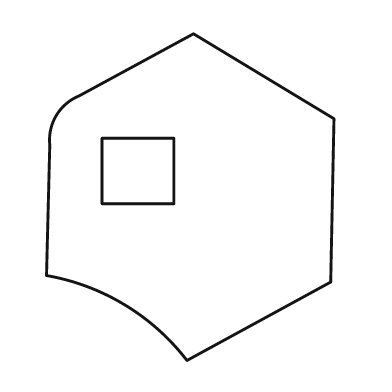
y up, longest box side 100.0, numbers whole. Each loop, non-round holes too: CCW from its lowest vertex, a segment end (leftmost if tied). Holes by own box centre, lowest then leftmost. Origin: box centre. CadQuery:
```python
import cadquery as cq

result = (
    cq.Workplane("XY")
    .moveTo(-1.0, -50.0)
    .lineTo(43.0, -26.0)
    .lineTo(44.0, 24.0)
    .lineTo(1.0, 50.0)
    .lineTo(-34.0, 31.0)
    .threePointArc((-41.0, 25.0), (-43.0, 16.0))
    .lineTo(-44.0, -24.0)
    .threePointArc((-20.0, -33.0), (-1.0, -50.0))
    .close()
    .moveTo(-27.0, -2.0)
    .lineTo(-5.0, -2.0)
    .lineTo(-5.0, 18.0)
    .lineTo(-27.0, 18.0)
    .close()
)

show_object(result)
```